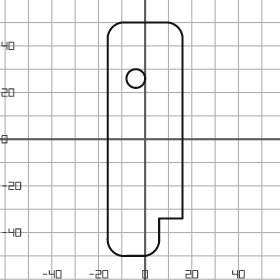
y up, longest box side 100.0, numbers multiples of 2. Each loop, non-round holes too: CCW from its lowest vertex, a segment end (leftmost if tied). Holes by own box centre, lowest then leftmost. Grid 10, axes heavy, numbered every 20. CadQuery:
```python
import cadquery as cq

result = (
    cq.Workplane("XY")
    .moveTo(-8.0, -50.0)
    .lineTo(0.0, -50.0)
    .threePointArc((4.0, -48.0), (6.0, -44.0))
    .lineTo(6.0, -34.0)
    .lineTo(16.0, -34.0)
    .lineTo(16.0, 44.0)
    .threePointArc((14.0, 48.0), (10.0, 50.0))
    .lineTo(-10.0, 50.0)
    .threePointArc((-14.0, 48.0), (-16.0, 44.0))
    .lineTo(-16.0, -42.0)
    .threePointArc((-14.0, -48.0), (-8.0, -50.0))
    .close()
    .moveTo(-4.0, 26.0)
    .circle(4.0)
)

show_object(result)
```